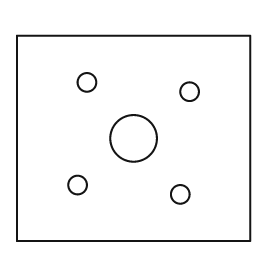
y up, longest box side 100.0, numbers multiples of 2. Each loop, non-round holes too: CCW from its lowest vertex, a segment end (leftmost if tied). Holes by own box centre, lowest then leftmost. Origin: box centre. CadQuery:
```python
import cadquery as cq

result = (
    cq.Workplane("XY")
    .moveTo(-50.0, -44.0)
    .lineTo(50.0, -44.0)
    .lineTo(50.0, 44.0)
    .lineTo(-50.0, 44.0)
    .close()
    .moveTo(20.0, -24.0)
    .circle(4.0)
    .moveTo(-24.0, -20.0)
    .circle(4.0)
    .moveTo(0.0, 0.0)
    .circle(10.0)
    .moveTo(24.0, 20.0)
    .circle(4.0)
    .moveTo(-20.0, 24.0)
    .circle(4.0)
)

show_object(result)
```